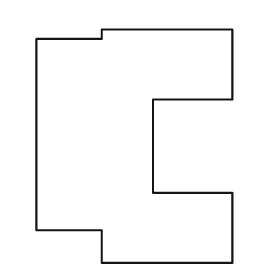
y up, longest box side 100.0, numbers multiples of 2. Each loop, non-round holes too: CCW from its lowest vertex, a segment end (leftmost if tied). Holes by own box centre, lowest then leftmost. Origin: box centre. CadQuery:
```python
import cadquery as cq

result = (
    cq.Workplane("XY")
    .moveTo(-14.0, -50.0)
    .lineTo(42.0, -50.0)
    .lineTo(42.0, -20.0)
    .lineTo(8.0, -20.0)
    .lineTo(8.0, 20.0)
    .lineTo(42.0, 20.0)
    .lineTo(42.0, 50.0)
    .lineTo(-14.0, 50.0)
    .lineTo(-14.0, 46.0)
    .lineTo(-42.0, 46.0)
    .lineTo(-42.0, -36.0)
    .lineTo(-14.0, -36.0)
    .close()
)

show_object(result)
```